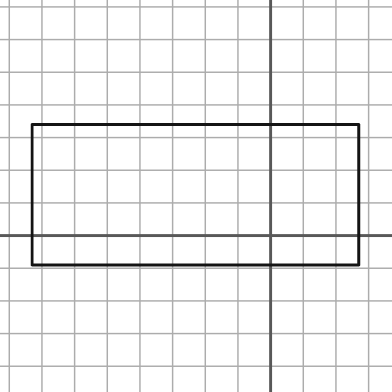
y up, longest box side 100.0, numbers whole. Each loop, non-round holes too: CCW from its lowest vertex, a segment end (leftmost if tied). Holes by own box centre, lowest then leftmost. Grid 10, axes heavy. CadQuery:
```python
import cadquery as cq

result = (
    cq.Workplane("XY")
    .moveTo(-73.0, -9.0)
    .lineTo(27.0, -9.0)
    .lineTo(27.0, 34.0)
    .lineTo(-73.0, 34.0)
    .close()
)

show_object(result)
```